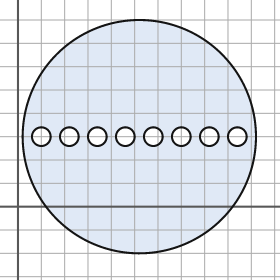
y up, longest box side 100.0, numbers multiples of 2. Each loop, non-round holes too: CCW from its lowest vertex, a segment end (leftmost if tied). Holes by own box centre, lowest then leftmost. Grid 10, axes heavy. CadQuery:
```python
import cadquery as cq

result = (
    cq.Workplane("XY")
    .moveTo(52.0, 30.0)
    .circle(50.0)
    .moveTo(10.0, 30.0)
    .circle(4.0)
    .moveTo(22.0, 30.0)
    .circle(4.0)
    .moveTo(34.0, 30.0)
    .circle(4.0)
    .moveTo(46.0, 30.0)
    .circle(4.0)
    .moveTo(58.0, 30.0)
    .circle(4.0)
    .moveTo(70.0, 30.0)
    .circle(4.0)
    .moveTo(82.0, 30.0)
    .circle(4.0)
    .moveTo(94.0, 30.0)
    .circle(4.0)
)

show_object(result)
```